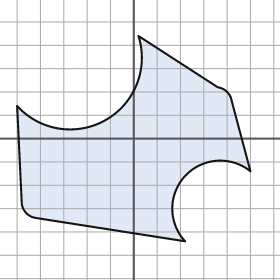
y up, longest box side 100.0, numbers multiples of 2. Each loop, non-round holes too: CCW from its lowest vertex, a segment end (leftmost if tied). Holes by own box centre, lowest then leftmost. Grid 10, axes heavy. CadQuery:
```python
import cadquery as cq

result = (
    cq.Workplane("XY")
    .moveTo(22.0, -44.0)
    .threePointArc((22.0, -16.0), (50.0, -14.0))
    .lineTo(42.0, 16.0)
    .threePointArc((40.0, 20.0), (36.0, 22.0))
    .lineTo(2.0, 44.0)
    .threePointArc((-12.0, 8.0), (-50.0, 14.0))
    .lineTo(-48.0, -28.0)
    .threePointArc((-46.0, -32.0), (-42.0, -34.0))
    .close()
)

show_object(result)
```